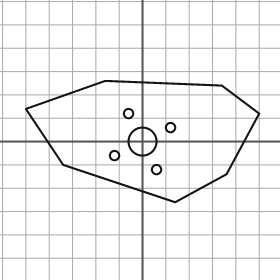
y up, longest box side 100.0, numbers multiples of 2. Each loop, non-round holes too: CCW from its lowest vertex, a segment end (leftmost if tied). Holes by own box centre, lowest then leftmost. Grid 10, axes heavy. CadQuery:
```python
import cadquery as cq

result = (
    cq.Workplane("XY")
    .moveTo(14.0, -26.0)
    .lineTo(36.0, -14.0)
    .lineTo(50.0, 12.0)
    .lineTo(34.0, 24.0)
    .lineTo(-16.0, 26.0)
    .lineTo(-50.0, 14.0)
    .lineTo(-34.0, -10.0)
    .close()
    .moveTo(6.0, -12.0)
    .circle(2.0)
    .moveTo(-12.0, -6.0)
    .circle(2.0)
    .moveTo(0.0, 0.0)
    .circle(6.0)
    .moveTo(12.0, 6.0)
    .circle(2.0)
    .moveTo(-6.0, 12.0)
    .circle(2.0)
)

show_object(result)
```